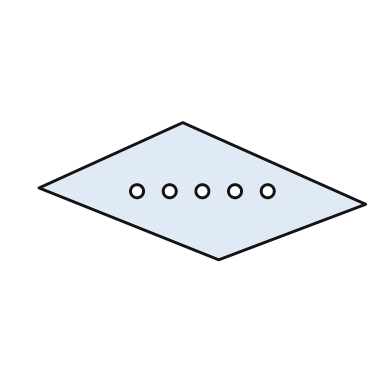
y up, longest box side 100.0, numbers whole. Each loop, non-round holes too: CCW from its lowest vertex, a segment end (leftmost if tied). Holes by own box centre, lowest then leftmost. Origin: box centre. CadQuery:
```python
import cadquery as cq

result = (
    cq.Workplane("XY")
    .moveTo(5.0, -21.0)
    .lineTo(50.0, -4.0)
    .lineTo(-6.0, 21.0)
    .lineTo(-50.0, 1.0)
    .close()
    .moveTo(-20.0, 0.0)
    .circle(2.0)
    .moveTo(-10.0, 0.0)
    .circle(2.0)
    .moveTo(0.0, 0.0)
    .circle(2.0)
    .moveTo(10.0, 0.0)
    .circle(2.0)
    .moveTo(20.0, 0.0)
    .circle(2.0)
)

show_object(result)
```